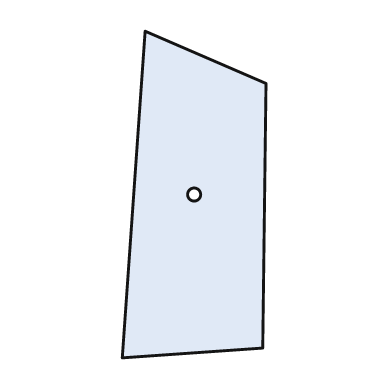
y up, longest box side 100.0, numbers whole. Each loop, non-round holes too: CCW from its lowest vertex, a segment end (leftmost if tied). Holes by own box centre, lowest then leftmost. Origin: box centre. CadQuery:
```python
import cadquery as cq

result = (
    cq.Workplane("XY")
    .moveTo(-22.0, -50.0)
    .lineTo(21.0, -47.0)
    .lineTo(22.0, 34.0)
    .lineTo(-15.0, 50.0)
    .close()
    .moveTo(0.0, 0.0)
    .circle(2.0)
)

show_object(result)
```